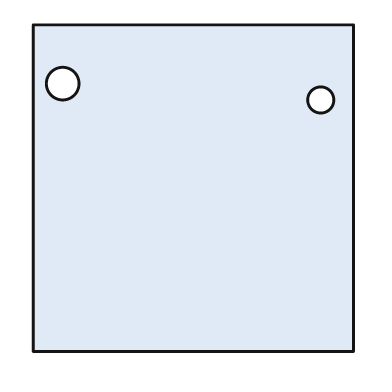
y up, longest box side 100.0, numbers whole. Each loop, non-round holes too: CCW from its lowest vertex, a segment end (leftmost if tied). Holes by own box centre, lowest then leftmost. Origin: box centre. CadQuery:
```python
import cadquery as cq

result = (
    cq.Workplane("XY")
    .moveTo(-49.0, -50.0)
    .lineTo(49.0, -50.0)
    .lineTo(49.0, 50.0)
    .lineTo(-49.0, 50.0)
    .close()
    .moveTo(39.0, 27.0)
    .circle(4.0)
    .moveTo(-40.0, 32.0)
    .circle(5.0)
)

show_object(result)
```